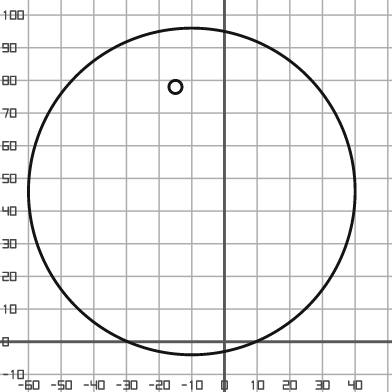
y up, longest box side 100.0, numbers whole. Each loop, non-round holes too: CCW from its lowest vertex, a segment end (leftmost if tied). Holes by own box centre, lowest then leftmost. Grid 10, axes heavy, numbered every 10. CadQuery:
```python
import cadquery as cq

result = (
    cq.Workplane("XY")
    .moveTo(-10.0, 46.0)
    .circle(50.0)
    .moveTo(-15.0, 78.0)
    .circle(2.0)
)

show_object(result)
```